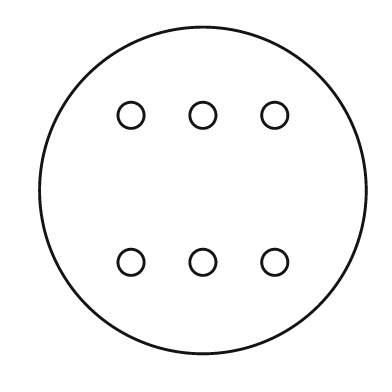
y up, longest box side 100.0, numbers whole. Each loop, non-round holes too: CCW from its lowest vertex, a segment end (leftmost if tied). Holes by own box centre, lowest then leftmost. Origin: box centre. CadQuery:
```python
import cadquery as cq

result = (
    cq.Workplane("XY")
    .moveTo(0.0, 0.0)
    .circle(50.0)
    .moveTo(-22.0, -22.0)
    .circle(4.0)
    .moveTo(0.0, -22.0)
    .circle(4.0)
    .moveTo(22.0, -22.0)
    .circle(4.0)
    .moveTo(-22.0, 23.0)
    .circle(4.0)
    .moveTo(0.0, 23.0)
    .circle(4.0)
    .moveTo(22.0, 23.0)
    .circle(4.0)
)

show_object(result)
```